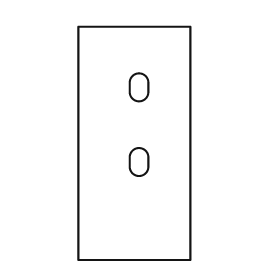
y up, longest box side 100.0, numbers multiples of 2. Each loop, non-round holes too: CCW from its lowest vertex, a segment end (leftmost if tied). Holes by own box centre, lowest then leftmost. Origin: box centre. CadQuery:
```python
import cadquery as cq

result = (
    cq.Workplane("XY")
    .moveTo(-24.0, -50.0)
    .lineTo(24.0, -50.0)
    .lineTo(24.0, 50.0)
    .lineTo(-24.0, 50.0)
    .close()
    .moveTo(-2.0, -10.0)
    .threePointArc((2.0, -14.0), (6.0, -10.0))
    .lineTo(6.0, -6.0)
    .threePointArc((2.0, -2.0), (-2.0, -6.0))
    .close()
    .moveTo(-2.0, 22.0)
    .threePointArc((2.0, 18.0), (6.0, 22.0))
    .lineTo(6.0, 26.0)
    .threePointArc((2.0, 30.0), (-2.0, 26.0))
    .close()
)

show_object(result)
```